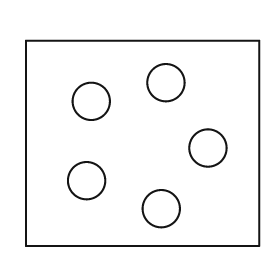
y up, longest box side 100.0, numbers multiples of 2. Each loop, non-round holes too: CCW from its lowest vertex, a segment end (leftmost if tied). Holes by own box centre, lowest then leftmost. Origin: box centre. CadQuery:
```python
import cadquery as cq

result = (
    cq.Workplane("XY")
    .moveTo(-50.0, -44.0)
    .lineTo(50.0, -44.0)
    .lineTo(50.0, 44.0)
    .lineTo(-50.0, 44.0)
    .close()
    .moveTo(8.0, -28.0)
    .circle(8.0)
    .moveTo(-24.0, -16.0)
    .circle(8.0)
    .moveTo(28.0, -2.0)
    .circle(8.0)
    .moveTo(-22.0, 18.0)
    .circle(8.0)
    .moveTo(10.0, 26.0)
    .circle(8.0)
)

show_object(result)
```